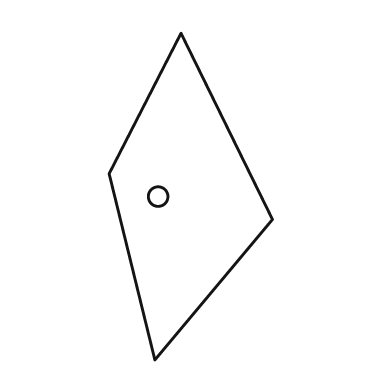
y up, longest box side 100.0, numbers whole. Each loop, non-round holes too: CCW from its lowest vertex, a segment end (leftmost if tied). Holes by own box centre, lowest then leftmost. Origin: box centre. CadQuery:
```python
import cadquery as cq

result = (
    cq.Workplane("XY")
    .moveTo(-11.0, -50.0)
    .lineTo(25.0, -7.0)
    .lineTo(-3.0, 50.0)
    .lineTo(-25.0, 7.0)
    .close()
    .moveTo(-10.0, 0.0)
    .circle(3.0)
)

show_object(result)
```